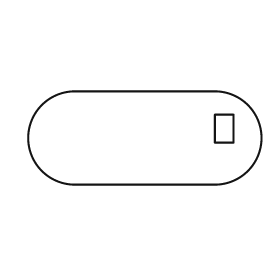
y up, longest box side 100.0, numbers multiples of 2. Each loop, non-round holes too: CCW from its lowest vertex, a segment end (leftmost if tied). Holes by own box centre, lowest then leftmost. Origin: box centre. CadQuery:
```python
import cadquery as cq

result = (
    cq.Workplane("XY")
    .moveTo(-30.0, -20.0)
    .lineTo(30.0, -20.0)
    .threePointArc((50.0, 0.0), (30.0, 20.0))
    .lineTo(-30.0, 20.0)
    .threePointArc((-50.0, 0.0), (-30.0, -20.0))
    .close()
    .moveTo(30.0, -2.0)
    .lineTo(38.0, -2.0)
    .lineTo(38.0, 10.0)
    .lineTo(30.0, 10.0)
    .close()
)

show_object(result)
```